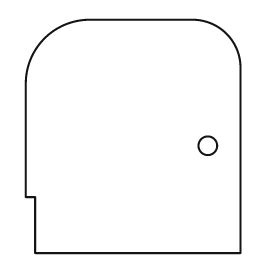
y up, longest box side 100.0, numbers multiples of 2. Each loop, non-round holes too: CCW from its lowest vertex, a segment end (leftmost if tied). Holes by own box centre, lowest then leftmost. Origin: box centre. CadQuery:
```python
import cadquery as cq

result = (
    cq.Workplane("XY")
    .moveTo(-42.0, -50.0)
    .lineTo(46.0, -50.0)
    .lineTo(46.0, 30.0)
    .threePointArc((40.0, 44.0), (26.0, 50.0))
    .lineTo(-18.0, 50.0)
    .threePointArc((-38.0, 42.0), (-46.0, 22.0))
    .lineTo(-46.0, -26.0)
    .lineTo(-42.0, -26.0)
    .close()
    .moveTo(32.0, -4.0)
    .circle(4.0)
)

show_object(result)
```